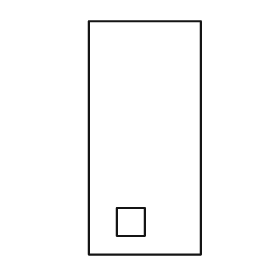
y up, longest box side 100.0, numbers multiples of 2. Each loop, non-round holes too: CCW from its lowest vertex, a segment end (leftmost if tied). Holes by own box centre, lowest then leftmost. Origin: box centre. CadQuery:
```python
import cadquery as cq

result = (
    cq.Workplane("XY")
    .moveTo(-24.0, -50.0)
    .lineTo(24.0, -50.0)
    .lineTo(24.0, 50.0)
    .lineTo(-24.0, 50.0)
    .close()
    .moveTo(-12.0, -42.0)
    .lineTo(0.0, -42.0)
    .lineTo(0.0, -30.0)
    .lineTo(-12.0, -30.0)
    .close()
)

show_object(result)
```